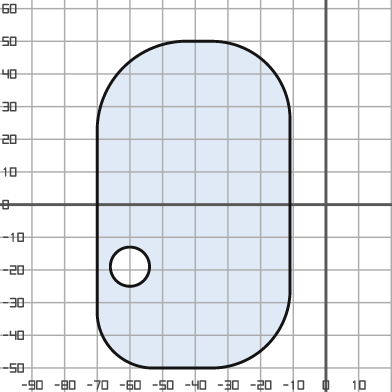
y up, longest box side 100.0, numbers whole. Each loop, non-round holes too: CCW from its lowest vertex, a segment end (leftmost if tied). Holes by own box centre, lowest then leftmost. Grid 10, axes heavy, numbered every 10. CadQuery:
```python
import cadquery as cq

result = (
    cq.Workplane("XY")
    .moveTo(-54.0, -50.0)
    .lineTo(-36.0, -50.0)
    .threePointArc((-18.0, -43.0), (-11.0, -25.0))
    .lineTo(-11.0, 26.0)
    .threePointArc((-18.0, 43.0), (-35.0, 50.0))
    .lineTo(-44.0, 50.0)
    .threePointArc((-62.0, 42.0), (-70.0, 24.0))
    .lineTo(-70.0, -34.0)
    .threePointArc((-65.0, -45.0), (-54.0, -50.0))
    .close()
    .moveTo(-60.0, -19.0)
    .circle(6.0)
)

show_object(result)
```